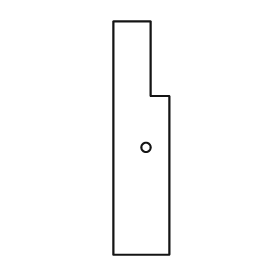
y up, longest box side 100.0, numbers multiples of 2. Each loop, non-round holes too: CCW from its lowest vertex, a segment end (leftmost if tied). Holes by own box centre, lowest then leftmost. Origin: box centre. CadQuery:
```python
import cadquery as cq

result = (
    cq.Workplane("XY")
    .moveTo(-12.0, -50.0)
    .lineTo(12.0, -50.0)
    .lineTo(12.0, 18.0)
    .lineTo(4.0, 18.0)
    .lineTo(4.0, 50.0)
    .lineTo(-12.0, 50.0)
    .close()
    .moveTo(2.0, -4.0)
    .circle(2.0)
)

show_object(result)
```